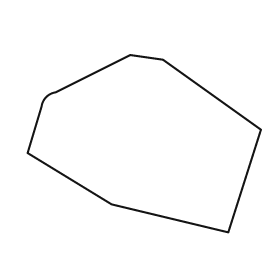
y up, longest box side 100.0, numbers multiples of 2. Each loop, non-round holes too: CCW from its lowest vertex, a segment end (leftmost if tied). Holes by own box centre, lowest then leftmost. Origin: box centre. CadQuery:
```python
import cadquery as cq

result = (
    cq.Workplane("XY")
    .moveTo(36.0, -38.0)
    .lineTo(50.0, 6.0)
    .lineTo(8.0, 36.0)
    .lineTo(-6.0, 38.0)
    .lineTo(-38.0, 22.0)
    .threePointArc((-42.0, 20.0), (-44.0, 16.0))
    .lineTo(-50.0, -4.0)
    .lineTo(-14.0, -26.0)
    .close()
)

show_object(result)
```